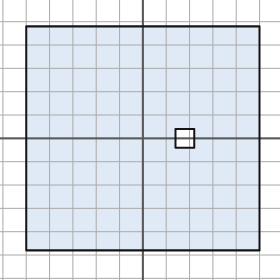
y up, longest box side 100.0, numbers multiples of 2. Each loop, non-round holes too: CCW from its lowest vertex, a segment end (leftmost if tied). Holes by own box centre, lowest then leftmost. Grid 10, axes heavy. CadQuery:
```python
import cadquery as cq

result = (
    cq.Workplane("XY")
    .moveTo(-50.0, -48.0)
    .lineTo(50.0, -48.0)
    .lineTo(50.0, 48.0)
    .lineTo(-50.0, 48.0)
    .close()
    .moveTo(14.0, -4.0)
    .lineTo(22.0, -4.0)
    .lineTo(22.0, 4.0)
    .lineTo(14.0, 4.0)
    .close()
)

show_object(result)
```